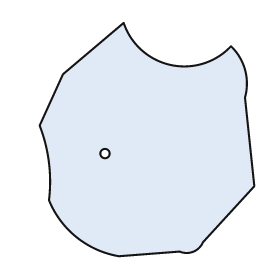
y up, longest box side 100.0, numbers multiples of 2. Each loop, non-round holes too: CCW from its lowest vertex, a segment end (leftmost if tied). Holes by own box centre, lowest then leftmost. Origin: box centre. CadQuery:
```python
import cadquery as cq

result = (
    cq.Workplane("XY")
    .moveTo(-12.0, -50.0)
    .lineTo(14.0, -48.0)
    .threePointArc((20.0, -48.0), (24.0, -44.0))
    .lineTo(46.0, -20.0)
    .lineTo(42.0, 18.0)
    .threePointArc((42.0, 30.0), (36.0, 40.0))
    .threePointArc((10.0, 32.0), (-10.0, 50.0))
    .lineTo(-36.0, 28.0)
    .lineTo(-46.0, 6.0)
    .threePointArc((-42.0, -10.0), (-42.0, -26.0))
    .threePointArc((-30.0, -42.0), (-12.0, -50.0))
    .close()
    .moveTo(-18.0, -6.0)
    .circle(2.0)
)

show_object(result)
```